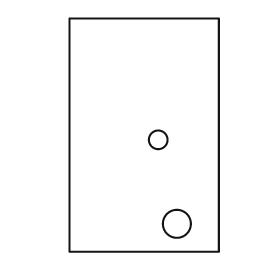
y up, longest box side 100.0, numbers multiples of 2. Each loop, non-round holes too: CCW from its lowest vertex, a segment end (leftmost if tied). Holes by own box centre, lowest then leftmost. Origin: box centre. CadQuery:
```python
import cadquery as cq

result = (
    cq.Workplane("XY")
    .moveTo(-32.0, -50.0)
    .lineTo(32.0, -50.0)
    .lineTo(32.0, 50.0)
    .lineTo(-32.0, 50.0)
    .close()
    .moveTo(14.0, -38.0)
    .circle(6.0)
    .moveTo(6.0, -2.0)
    .circle(4.0)
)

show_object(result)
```